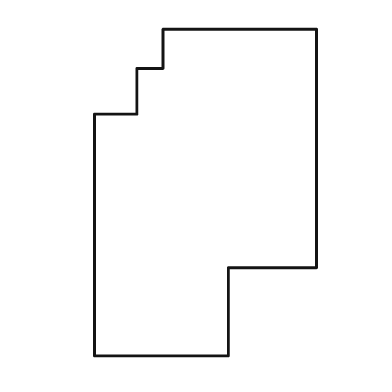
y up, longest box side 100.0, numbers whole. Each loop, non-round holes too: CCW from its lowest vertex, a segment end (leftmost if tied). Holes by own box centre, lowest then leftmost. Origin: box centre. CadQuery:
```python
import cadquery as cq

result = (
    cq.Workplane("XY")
    .moveTo(-34.0, -50.0)
    .lineTo(7.0, -50.0)
    .lineTo(7.0, -23.0)
    .lineTo(34.0, -23.0)
    .lineTo(34.0, 50.0)
    .lineTo(-13.0, 50.0)
    .lineTo(-13.0, 38.0)
    .lineTo(-21.0, 38.0)
    .lineTo(-21.0, 24.0)
    .lineTo(-34.0, 24.0)
    .close()
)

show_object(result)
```